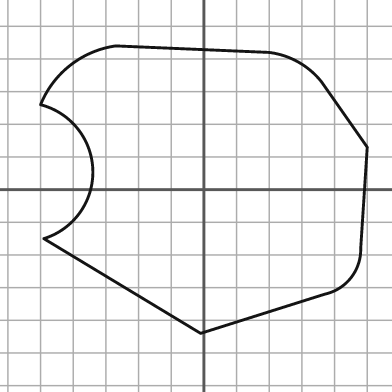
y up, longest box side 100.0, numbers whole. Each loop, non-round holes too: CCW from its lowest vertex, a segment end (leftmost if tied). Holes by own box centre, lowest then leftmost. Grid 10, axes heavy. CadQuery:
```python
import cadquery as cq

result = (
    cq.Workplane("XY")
    .moveTo(-1.0, -44.0)
    .lineTo(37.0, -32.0)
    .threePointArc((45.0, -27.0), (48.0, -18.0))
    .lineTo(50.0, 13.0)
    .lineTo(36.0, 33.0)
    .threePointArc((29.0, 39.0), (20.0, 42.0))
    .lineTo(-27.0, 44.0)
    .threePointArc((-41.0, 38.0), (-50.0, 26.0))
    .threePointArc((-34.0, 6.0), (-49.0, -15.0))
    .close()
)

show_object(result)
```